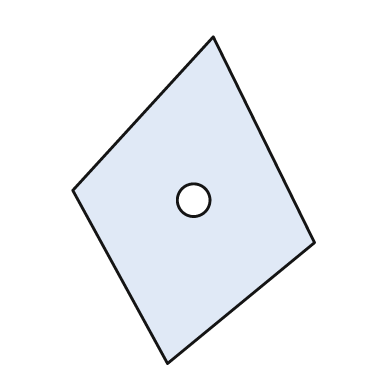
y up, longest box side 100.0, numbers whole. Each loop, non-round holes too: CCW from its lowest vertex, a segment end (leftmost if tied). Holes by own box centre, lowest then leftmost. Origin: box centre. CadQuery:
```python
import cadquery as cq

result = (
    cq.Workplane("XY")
    .moveTo(-8.0, -50.0)
    .lineTo(37.0, -13.0)
    .lineTo(6.0, 50.0)
    .lineTo(-37.0, 3.0)
    .close()
    .moveTo(0.0, 0.0)
    .circle(5.0)
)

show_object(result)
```